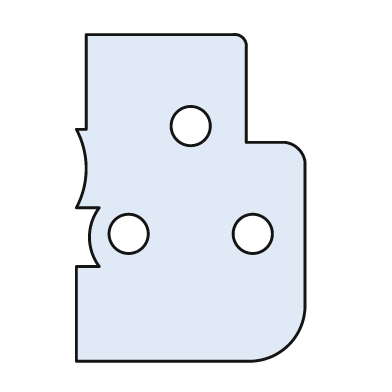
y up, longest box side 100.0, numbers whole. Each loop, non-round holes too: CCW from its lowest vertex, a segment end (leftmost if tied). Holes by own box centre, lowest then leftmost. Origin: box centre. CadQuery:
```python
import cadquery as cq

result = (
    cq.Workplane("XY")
    .moveTo(-35.0, -50.0)
    .lineTo(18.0, -50.0)
    .threePointArc((30.0, -45.0), (35.0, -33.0))
    .lineTo(35.0, 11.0)
    .threePointArc((33.0, 15.0), (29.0, 17.0))
    .lineTo(17.0, 17.0)
    .lineTo(17.0, 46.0)
    .threePointArc((16.0, 49.0), (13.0, 50.0))
    .lineTo(-32.0, 50.0)
    .lineTo(-32.0, 21.0)
    .lineTo(-35.0, 21.0)
    .threePointArc((-32.0, 9.0), (-35.0, -3.0))
    .lineTo(-28.0, -3.0)
    .threePointArc((-31.0, -12.0), (-28.0, -21.0))
    .lineTo(-35.0, -21.0)
    .close()
    .moveTo(-19.0, -11.0)
    .circle(6.0)
    .moveTo(19.0, -11.0)
    .circle(6.0)
    .moveTo(0.0, 22.0)
    .circle(6.0)
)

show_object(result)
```